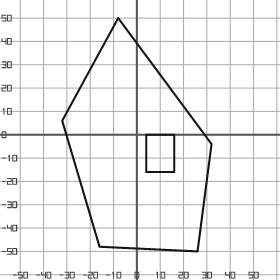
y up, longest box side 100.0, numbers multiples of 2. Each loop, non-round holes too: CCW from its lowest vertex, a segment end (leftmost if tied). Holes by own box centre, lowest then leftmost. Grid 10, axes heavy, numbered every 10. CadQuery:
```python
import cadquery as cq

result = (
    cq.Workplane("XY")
    .moveTo(26.0, -50.0)
    .lineTo(32.0, -4.0)
    .lineTo(-8.0, 50.0)
    .lineTo(-32.0, 6.0)
    .lineTo(-16.0, -48.0)
    .close()
    .moveTo(4.0, -16.0)
    .lineTo(16.0, -16.0)
    .lineTo(16.0, 0.0)
    .lineTo(4.0, 0.0)
    .close()
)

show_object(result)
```